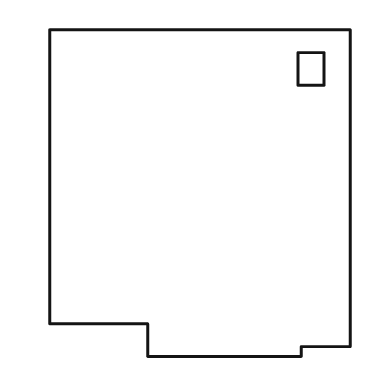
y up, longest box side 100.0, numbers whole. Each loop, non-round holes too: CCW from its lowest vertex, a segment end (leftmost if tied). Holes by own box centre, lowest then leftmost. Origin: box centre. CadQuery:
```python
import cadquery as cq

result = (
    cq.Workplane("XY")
    .moveTo(-16.0, -50.0)
    .lineTo(31.0, -50.0)
    .lineTo(31.0, -47.0)
    .lineTo(46.0, -47.0)
    .lineTo(46.0, 50.0)
    .lineTo(-46.0, 50.0)
    .lineTo(-46.0, -40.0)
    .lineTo(-16.0, -40.0)
    .close()
    .moveTo(30.0, 33.0)
    .lineTo(38.0, 33.0)
    .lineTo(38.0, 43.0)
    .lineTo(30.0, 43.0)
    .close()
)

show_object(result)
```